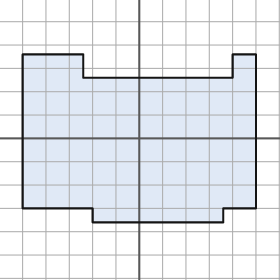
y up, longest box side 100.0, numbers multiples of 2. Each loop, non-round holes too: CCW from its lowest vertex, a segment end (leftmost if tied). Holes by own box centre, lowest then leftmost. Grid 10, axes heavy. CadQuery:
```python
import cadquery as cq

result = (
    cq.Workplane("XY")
    .moveTo(-20.0, -36.0)
    .lineTo(36.0, -36.0)
    .lineTo(36.0, -30.0)
    .lineTo(50.0, -30.0)
    .lineTo(50.0, 36.0)
    .lineTo(40.0, 36.0)
    .lineTo(40.0, 26.0)
    .lineTo(-24.0, 26.0)
    .lineTo(-24.0, 36.0)
    .lineTo(-50.0, 36.0)
    .lineTo(-50.0, -30.0)
    .lineTo(-20.0, -30.0)
    .close()
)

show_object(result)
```